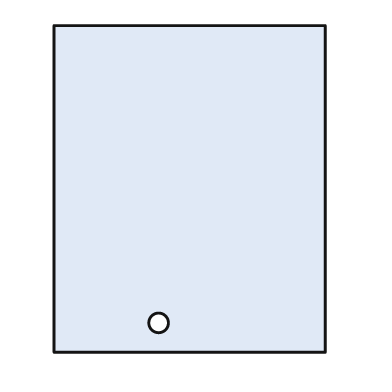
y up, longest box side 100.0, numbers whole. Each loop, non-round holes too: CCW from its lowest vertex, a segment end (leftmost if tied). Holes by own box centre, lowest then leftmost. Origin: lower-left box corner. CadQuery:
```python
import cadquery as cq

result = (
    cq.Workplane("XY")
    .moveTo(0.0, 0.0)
    .lineTo(83.0, 0.0)
    .lineTo(83.0, 100.0)
    .lineTo(0.0, 100.0)
    .close()
    .moveTo(32.0, 9.0)
    .circle(3.0)
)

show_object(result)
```